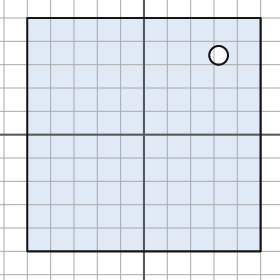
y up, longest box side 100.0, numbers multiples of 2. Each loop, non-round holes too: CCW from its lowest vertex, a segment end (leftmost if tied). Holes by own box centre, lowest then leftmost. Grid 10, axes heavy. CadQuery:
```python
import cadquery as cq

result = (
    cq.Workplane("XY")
    .moveTo(-50.0, -50.0)
    .lineTo(50.0, -50.0)
    .lineTo(50.0, 50.0)
    .lineTo(-50.0, 50.0)
    .close()
    .moveTo(32.0, 34.0)
    .circle(4.0)
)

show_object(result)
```